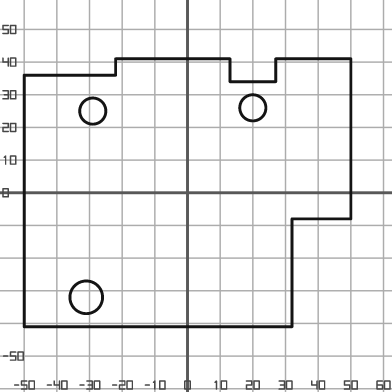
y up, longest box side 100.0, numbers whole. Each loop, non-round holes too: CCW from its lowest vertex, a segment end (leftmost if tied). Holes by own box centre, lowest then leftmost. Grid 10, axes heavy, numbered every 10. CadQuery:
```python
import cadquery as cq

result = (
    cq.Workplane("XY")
    .moveTo(-50.0, -41.0)
    .lineTo(32.0, -41.0)
    .lineTo(32.0, -8.0)
    .lineTo(50.0, -8.0)
    .lineTo(50.0, 41.0)
    .lineTo(27.0, 41.0)
    .lineTo(27.0, 34.0)
    .lineTo(13.0, 34.0)
    .lineTo(13.0, 41.0)
    .lineTo(-22.0, 41.0)
    .lineTo(-22.0, 36.0)
    .lineTo(-50.0, 36.0)
    .close()
    .moveTo(-31.0, -32.0)
    .circle(5.0)
    .moveTo(-29.0, 25.0)
    .circle(4.0)
    .moveTo(20.0, 26.0)
    .circle(4.0)
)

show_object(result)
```